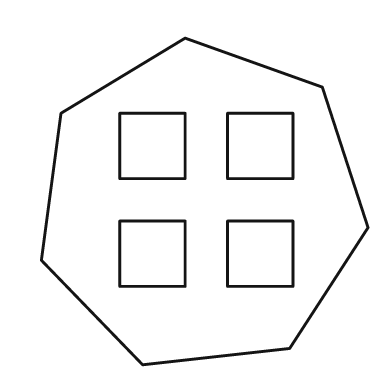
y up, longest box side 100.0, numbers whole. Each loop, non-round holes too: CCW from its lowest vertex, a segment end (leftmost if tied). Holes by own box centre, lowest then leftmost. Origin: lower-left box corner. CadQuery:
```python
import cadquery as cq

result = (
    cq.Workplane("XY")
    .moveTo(31.0, 0.0)
    .lineTo(76.0, 5.0)
    .lineTo(100.0, 42.0)
    .lineTo(86.0, 85.0)
    .lineTo(44.0, 100.0)
    .lineTo(6.0, 77.0)
    .lineTo(0.0, 32.0)
    .close()
    .moveTo(24.0, 24.0)
    .lineTo(44.0, 24.0)
    .lineTo(44.0, 44.0)
    .lineTo(24.0, 44.0)
    .close()
    .moveTo(57.0, 24.0)
    .lineTo(77.0, 24.0)
    .lineTo(77.0, 44.0)
    .lineTo(57.0, 44.0)
    .close()
    .moveTo(24.0, 57.0)
    .lineTo(44.0, 57.0)
    .lineTo(44.0, 77.0)
    .lineTo(24.0, 77.0)
    .close()
    .moveTo(57.0, 57.0)
    .lineTo(77.0, 57.0)
    .lineTo(77.0, 77.0)
    .lineTo(57.0, 77.0)
    .close()
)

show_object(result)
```